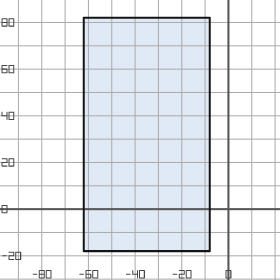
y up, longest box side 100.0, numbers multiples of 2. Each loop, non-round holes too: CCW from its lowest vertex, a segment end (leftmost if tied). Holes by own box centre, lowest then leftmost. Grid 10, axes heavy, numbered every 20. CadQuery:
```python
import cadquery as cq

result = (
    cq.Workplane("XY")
    .moveTo(-62.0, -18.0)
    .lineTo(-8.0, -18.0)
    .lineTo(-8.0, 82.0)
    .lineTo(-62.0, 82.0)
    .close()
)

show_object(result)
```